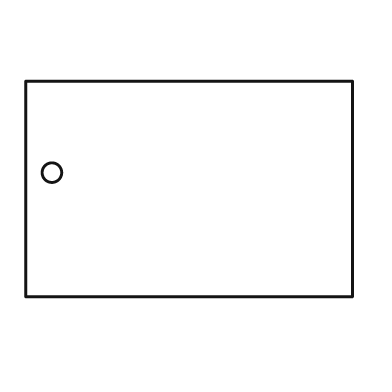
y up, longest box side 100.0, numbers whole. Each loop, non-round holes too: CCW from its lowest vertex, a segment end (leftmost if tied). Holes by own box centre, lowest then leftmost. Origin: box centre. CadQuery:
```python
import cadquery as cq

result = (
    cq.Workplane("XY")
    .moveTo(-50.0, -33.0)
    .lineTo(50.0, -33.0)
    .lineTo(50.0, 33.0)
    .lineTo(-50.0, 33.0)
    .close()
    .moveTo(-42.0, 5.0)
    .circle(3.0)
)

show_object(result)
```